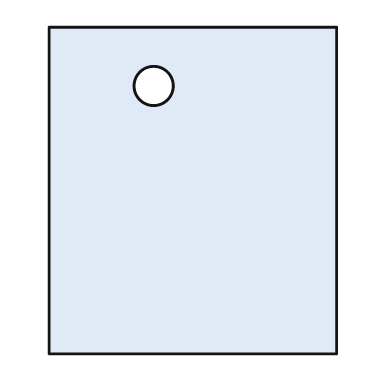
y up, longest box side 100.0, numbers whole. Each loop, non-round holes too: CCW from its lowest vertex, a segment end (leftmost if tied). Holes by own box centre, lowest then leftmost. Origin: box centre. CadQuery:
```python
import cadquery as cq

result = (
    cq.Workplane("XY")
    .moveTo(-44.0, -50.0)
    .lineTo(44.0, -50.0)
    .lineTo(44.0, 50.0)
    .lineTo(-44.0, 50.0)
    .close()
    .moveTo(-12.0, 32.0)
    .circle(6.0)
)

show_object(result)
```